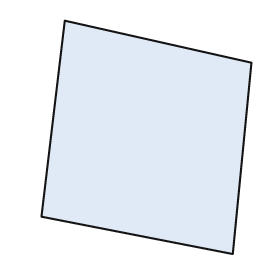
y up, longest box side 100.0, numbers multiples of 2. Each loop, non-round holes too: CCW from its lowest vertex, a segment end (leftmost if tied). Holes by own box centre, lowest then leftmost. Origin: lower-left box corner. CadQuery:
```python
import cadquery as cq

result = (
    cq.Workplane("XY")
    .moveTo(82.0, 0.0)
    .lineTo(90.0, 82.0)
    .lineTo(10.0, 100.0)
    .lineTo(0.0, 16.0)
    .close()
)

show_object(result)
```